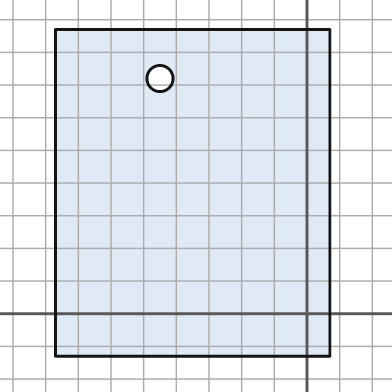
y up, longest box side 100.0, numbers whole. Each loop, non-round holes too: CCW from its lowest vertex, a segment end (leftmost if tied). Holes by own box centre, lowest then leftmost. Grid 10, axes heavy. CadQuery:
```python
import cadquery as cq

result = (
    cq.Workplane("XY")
    .moveTo(-77.0, -13.0)
    .lineTo(7.0, -13.0)
    .lineTo(7.0, 87.0)
    .lineTo(-77.0, 87.0)
    .close()
    .moveTo(-45.0, 72.0)
    .circle(4.0)
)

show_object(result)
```